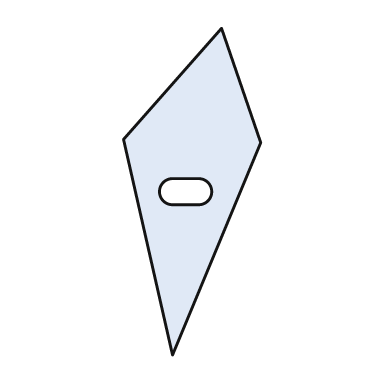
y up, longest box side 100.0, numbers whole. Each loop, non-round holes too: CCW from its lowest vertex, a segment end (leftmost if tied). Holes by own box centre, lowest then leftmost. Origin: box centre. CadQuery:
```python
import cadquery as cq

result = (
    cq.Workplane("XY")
    .moveTo(-6.0, -50.0)
    .lineTo(21.0, 15.0)
    .lineTo(9.0, 50.0)
    .lineTo(-21.0, 16.0)
    .close()
    .moveTo(-6.0, -4.0)
    .lineTo(2.0, -4.0)
    .threePointArc((6.0, 0.0), (2.0, 4.0))
    .lineTo(-6.0, 4.0)
    .threePointArc((-10.0, 0.0), (-6.0, -4.0))
    .close()
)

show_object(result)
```